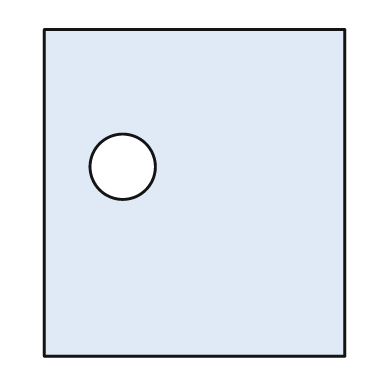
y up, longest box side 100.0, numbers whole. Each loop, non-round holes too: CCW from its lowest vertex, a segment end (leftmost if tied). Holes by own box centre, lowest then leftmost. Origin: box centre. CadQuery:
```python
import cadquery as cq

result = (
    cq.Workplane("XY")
    .moveTo(-46.0, -50.0)
    .lineTo(46.0, -50.0)
    .lineTo(46.0, 50.0)
    .lineTo(-46.0, 50.0)
    .close()
    .moveTo(-22.0, 8.0)
    .circle(10.0)
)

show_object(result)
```